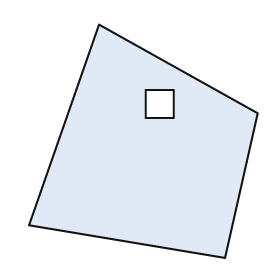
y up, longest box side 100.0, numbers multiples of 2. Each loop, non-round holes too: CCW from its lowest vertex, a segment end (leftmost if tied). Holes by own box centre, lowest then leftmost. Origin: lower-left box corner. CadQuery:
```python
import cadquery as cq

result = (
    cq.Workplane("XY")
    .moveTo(84.0, 0.0)
    .lineTo(98.0, 62.0)
    .lineTo(30.0, 100.0)
    .lineTo(0.0, 14.0)
    .close()
    .moveTo(50.0, 60.0)
    .lineTo(62.0, 60.0)
    .lineTo(62.0, 72.0)
    .lineTo(50.0, 72.0)
    .close()
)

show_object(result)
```